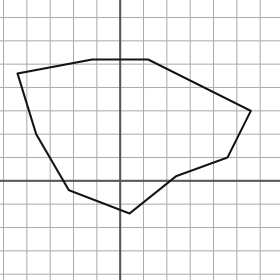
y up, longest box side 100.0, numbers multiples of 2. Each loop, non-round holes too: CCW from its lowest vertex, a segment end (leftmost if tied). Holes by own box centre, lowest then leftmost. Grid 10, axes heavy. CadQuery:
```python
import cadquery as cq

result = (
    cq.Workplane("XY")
    .moveTo(4.0, -14.0)
    .lineTo(24.0, 2.0)
    .lineTo(46.0, 10.0)
    .lineTo(56.0, 30.0)
    .lineTo(12.0, 52.0)
    .lineTo(-12.0, 52.0)
    .lineTo(-44.0, 46.0)
    .lineTo(-36.0, 20.0)
    .lineTo(-22.0, -4.0)
    .close()
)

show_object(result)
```